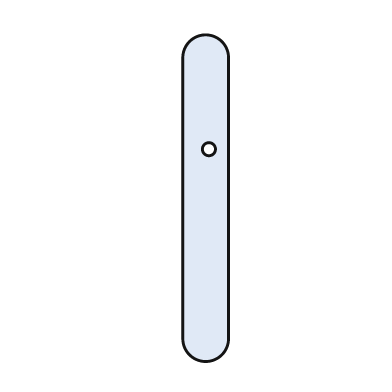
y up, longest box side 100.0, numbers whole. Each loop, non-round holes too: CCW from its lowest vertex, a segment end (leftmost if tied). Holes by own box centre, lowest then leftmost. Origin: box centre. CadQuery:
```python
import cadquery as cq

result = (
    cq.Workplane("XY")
    .moveTo(-7.0, -43.0)
    .threePointArc((0.0, -50.0), (7.0, -43.0))
    .lineTo(7.0, 43.0)
    .threePointArc((0.0, 50.0), (-7.0, 43.0))
    .close()
    .moveTo(1.0, 15.0)
    .circle(2.0)
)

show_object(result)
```